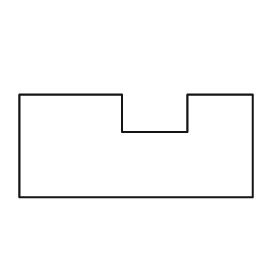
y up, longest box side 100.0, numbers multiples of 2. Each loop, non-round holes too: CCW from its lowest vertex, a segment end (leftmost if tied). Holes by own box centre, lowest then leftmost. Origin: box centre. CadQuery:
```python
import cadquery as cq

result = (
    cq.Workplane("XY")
    .moveTo(-50.0, -22.0)
    .lineTo(50.0, -22.0)
    .lineTo(50.0, 22.0)
    .lineTo(22.0, 22.0)
    .lineTo(22.0, 6.0)
    .lineTo(-6.0, 6.0)
    .lineTo(-6.0, 22.0)
    .lineTo(-50.0, 22.0)
    .close()
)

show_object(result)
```